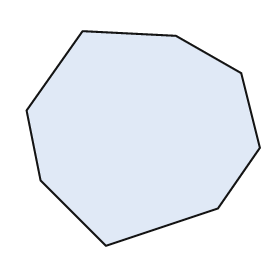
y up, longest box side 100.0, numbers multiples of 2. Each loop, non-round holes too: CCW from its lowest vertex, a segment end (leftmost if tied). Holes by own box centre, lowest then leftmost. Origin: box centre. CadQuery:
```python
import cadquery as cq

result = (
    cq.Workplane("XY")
    .moveTo(-16.0, -46.0)
    .lineTo(32.0, -30.0)
    .lineTo(50.0, -4.0)
    .lineTo(42.0, 28.0)
    .lineTo(14.0, 44.0)
    .lineTo(-26.0, 46.0)
    .lineTo(-50.0, 12.0)
    .lineTo(-44.0, -18.0)
    .close()
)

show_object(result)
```